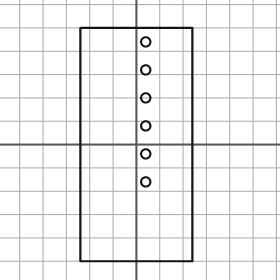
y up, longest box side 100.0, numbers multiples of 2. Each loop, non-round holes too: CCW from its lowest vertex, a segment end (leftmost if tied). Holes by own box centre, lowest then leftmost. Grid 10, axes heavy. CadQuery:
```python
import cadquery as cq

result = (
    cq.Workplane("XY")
    .moveTo(-24.0, -50.0)
    .lineTo(24.0, -50.0)
    .lineTo(24.0, 50.0)
    .lineTo(-24.0, 50.0)
    .close()
    .moveTo(4.0, -16.0)
    .circle(2.0)
    .moveTo(4.0, -4.0)
    .circle(2.0)
    .moveTo(4.0, 8.0)
    .circle(2.0)
    .moveTo(4.0, 20.0)
    .circle(2.0)
    .moveTo(4.0, 32.0)
    .circle(2.0)
    .moveTo(4.0, 44.0)
    .circle(2.0)
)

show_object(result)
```